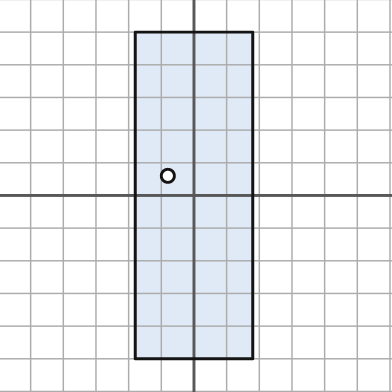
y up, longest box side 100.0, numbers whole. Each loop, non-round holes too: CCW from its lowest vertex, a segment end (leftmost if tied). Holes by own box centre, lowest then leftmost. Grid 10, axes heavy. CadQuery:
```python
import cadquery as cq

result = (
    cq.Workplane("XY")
    .moveTo(-18.0, -50.0)
    .lineTo(18.0, -50.0)
    .lineTo(18.0, 50.0)
    .lineTo(-18.0, 50.0)
    .close()
    .moveTo(-8.0, 6.0)
    .circle(2.0)
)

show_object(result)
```